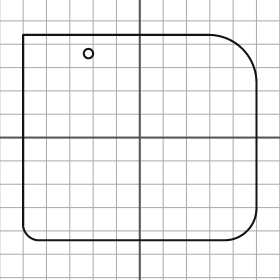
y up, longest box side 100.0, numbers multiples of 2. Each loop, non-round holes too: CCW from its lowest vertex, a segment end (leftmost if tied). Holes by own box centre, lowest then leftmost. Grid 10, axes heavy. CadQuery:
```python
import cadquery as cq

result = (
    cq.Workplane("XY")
    .moveTo(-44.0, -44.0)
    .lineTo(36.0, -44.0)
    .threePointArc((46.0, -40.0), (50.0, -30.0))
    .lineTo(50.0, 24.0)
    .threePointArc((44.0, 38.0), (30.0, 44.0))
    .lineTo(-50.0, 44.0)
    .lineTo(-50.0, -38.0)
    .threePointArc((-48.0, -42.0), (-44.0, -44.0))
    .close()
    .moveTo(-22.0, 36.0)
    .circle(2.0)
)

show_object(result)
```